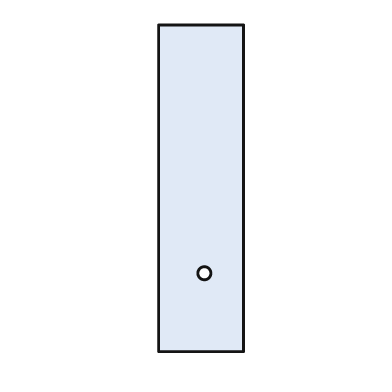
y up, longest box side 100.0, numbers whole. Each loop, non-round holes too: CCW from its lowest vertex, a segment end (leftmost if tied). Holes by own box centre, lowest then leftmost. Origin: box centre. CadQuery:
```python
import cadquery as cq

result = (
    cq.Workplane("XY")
    .moveTo(-13.0, -50.0)
    .lineTo(13.0, -50.0)
    .lineTo(13.0, 50.0)
    .lineTo(-13.0, 50.0)
    .close()
    .moveTo(1.0, -26.0)
    .circle(2.0)
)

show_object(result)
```